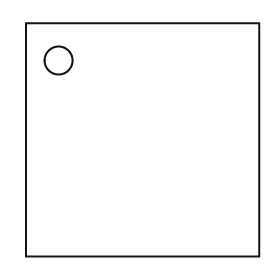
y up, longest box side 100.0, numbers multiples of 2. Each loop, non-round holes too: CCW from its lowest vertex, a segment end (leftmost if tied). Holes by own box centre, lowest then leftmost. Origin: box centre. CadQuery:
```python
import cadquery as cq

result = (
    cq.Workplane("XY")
    .moveTo(-50.0, -50.0)
    .lineTo(50.0, -50.0)
    .lineTo(50.0, 50.0)
    .lineTo(-50.0, 50.0)
    .close()
    .moveTo(-36.0, 34.0)
    .circle(6.0)
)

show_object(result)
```